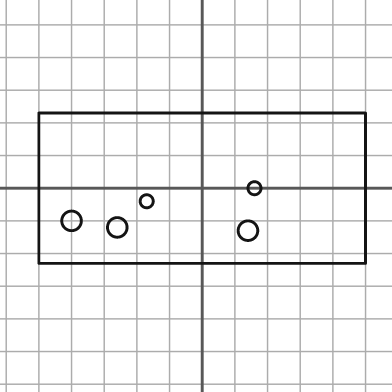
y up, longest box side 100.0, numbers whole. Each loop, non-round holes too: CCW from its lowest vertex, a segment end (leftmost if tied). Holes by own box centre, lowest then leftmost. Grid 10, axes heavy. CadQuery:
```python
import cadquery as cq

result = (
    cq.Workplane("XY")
    .moveTo(-50.0, -23.0)
    .lineTo(50.0, -23.0)
    .lineTo(50.0, 23.0)
    .lineTo(-50.0, 23.0)
    .close()
    .moveTo(14.0, -13.0)
    .circle(3.0)
    .moveTo(-26.0, -12.0)
    .circle(3.0)
    .moveTo(-40.0, -10.0)
    .circle(3.0)
    .moveTo(-17.0, -4.0)
    .circle(2.0)
    .moveTo(16.0, 0.0)
    .circle(2.0)
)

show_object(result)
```